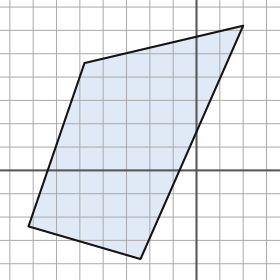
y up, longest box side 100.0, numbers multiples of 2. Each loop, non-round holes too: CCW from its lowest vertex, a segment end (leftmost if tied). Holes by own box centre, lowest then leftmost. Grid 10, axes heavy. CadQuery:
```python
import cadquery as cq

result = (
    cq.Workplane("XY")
    .moveTo(-24.0, -38.0)
    .lineTo(20.0, 62.0)
    .lineTo(-48.0, 46.0)
    .lineTo(-72.0, -24.0)
    .close()
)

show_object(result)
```